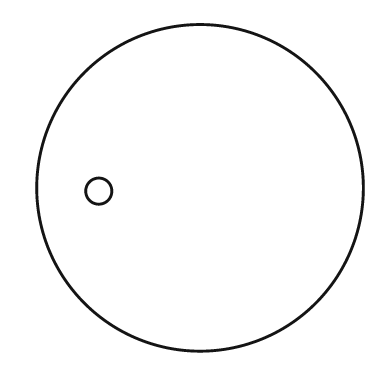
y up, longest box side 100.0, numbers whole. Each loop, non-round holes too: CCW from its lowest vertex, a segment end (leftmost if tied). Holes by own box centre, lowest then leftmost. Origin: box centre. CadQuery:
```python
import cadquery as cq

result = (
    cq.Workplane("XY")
    .moveTo(0.0, 0.0)
    .circle(50.0)
    .moveTo(-31.0, -1.0)
    .circle(4.0)
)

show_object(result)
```